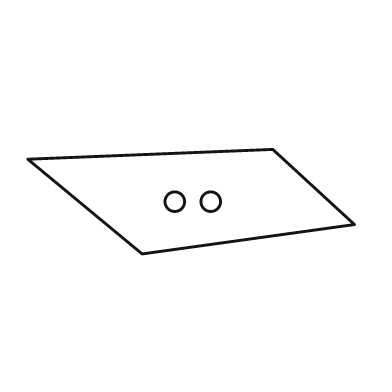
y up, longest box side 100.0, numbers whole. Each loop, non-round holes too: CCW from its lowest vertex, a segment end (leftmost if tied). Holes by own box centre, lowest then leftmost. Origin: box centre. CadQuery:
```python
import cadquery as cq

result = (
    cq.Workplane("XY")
    .moveTo(-15.0, -16.0)
    .lineTo(50.0, -7.0)
    .lineTo(25.0, 16.0)
    .lineTo(-50.0, 13.0)
    .close()
    .moveTo(-5.0, 0.0)
    .circle(3.0)
    .moveTo(6.0, 0.0)
    .circle(3.0)
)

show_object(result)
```